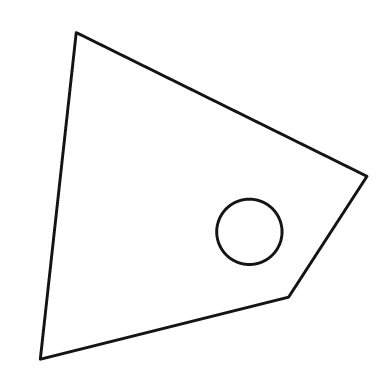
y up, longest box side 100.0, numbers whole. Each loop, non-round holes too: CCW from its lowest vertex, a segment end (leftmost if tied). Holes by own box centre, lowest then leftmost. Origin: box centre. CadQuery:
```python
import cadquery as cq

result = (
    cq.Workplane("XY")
    .moveTo(-50.0, -50.0)
    .lineTo(26.0, -31.0)
    .lineTo(50.0, 6.0)
    .lineTo(-39.0, 50.0)
    .close()
    .moveTo(14.0, -11.0)
    .circle(10.0)
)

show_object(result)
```